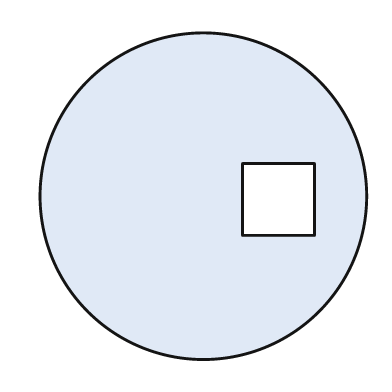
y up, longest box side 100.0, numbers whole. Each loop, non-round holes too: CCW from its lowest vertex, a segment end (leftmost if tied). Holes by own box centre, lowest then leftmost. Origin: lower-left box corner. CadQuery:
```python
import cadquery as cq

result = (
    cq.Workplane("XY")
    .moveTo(50.0, 50.0)
    .circle(50.0)
    .moveTo(62.0, 38.0)
    .lineTo(84.0, 38.0)
    .lineTo(84.0, 60.0)
    .lineTo(62.0, 60.0)
    .close()
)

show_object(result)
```